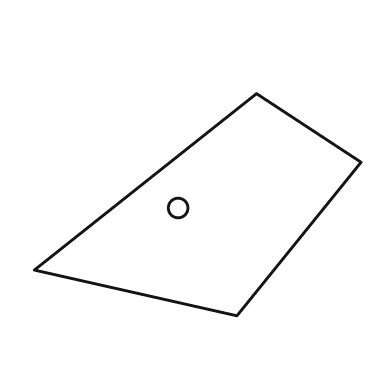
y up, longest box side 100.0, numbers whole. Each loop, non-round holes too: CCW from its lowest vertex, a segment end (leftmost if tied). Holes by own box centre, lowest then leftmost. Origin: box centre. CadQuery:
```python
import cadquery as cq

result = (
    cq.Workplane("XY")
    .moveTo(12.0, -34.0)
    .lineTo(50.0, 13.0)
    .lineTo(18.0, 34.0)
    .lineTo(-50.0, -20.0)
    .close()
    .moveTo(-6.0, -1.0)
    .circle(3.0)
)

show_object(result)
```